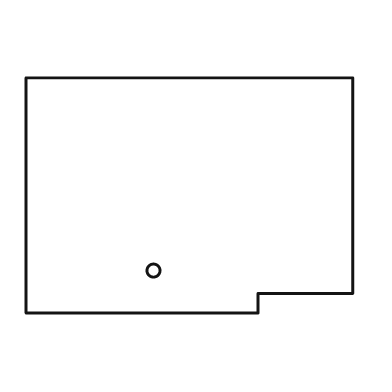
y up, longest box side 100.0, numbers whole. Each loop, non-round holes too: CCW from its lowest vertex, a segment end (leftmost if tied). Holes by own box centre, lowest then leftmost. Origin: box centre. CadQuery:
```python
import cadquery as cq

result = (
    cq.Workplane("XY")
    .moveTo(-50.0, -36.0)
    .lineTo(21.0, -36.0)
    .lineTo(21.0, -30.0)
    .lineTo(50.0, -30.0)
    .lineTo(50.0, 36.0)
    .lineTo(-50.0, 36.0)
    .close()
    .moveTo(-11.0, -23.0)
    .circle(2.0)
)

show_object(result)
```